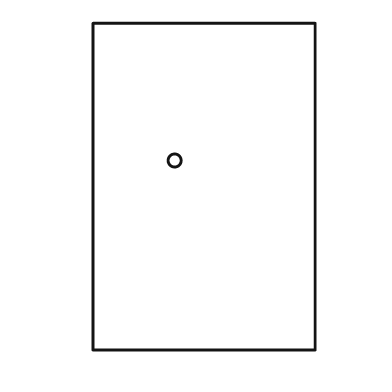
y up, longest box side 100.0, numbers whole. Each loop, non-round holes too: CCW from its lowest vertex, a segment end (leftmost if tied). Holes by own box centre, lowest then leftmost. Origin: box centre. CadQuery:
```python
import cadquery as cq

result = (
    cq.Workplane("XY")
    .moveTo(-34.0, -50.0)
    .lineTo(34.0, -50.0)
    .lineTo(34.0, 50.0)
    .lineTo(-34.0, 50.0)
    .close()
    .moveTo(-9.0, 8.0)
    .circle(2.0)
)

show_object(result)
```